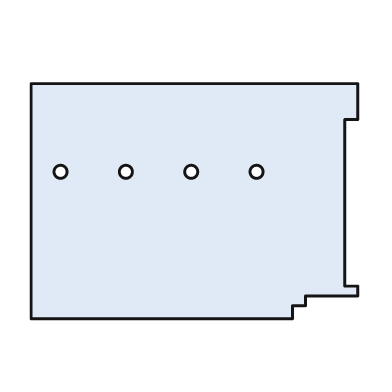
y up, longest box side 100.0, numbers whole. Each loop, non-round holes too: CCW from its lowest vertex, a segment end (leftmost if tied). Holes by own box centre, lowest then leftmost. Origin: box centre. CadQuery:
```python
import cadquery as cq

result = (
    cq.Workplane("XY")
    .moveTo(-50.0, -36.0)
    .lineTo(30.0, -36.0)
    .lineTo(30.0, -32.0)
    .lineTo(34.0, -32.0)
    .lineTo(34.0, -29.0)
    .lineTo(50.0, -29.0)
    .lineTo(50.0, -26.0)
    .lineTo(46.0, -26.0)
    .lineTo(46.0, 25.0)
    .lineTo(50.0, 25.0)
    .lineTo(50.0, 36.0)
    .lineTo(-50.0, 36.0)
    .close()
    .moveTo(-41.0, 9.0)
    .circle(2.0)
    .moveTo(-21.0, 9.0)
    .circle(2.0)
    .moveTo(-1.0, 9.0)
    .circle(2.0)
    .moveTo(19.0, 9.0)
    .circle(2.0)
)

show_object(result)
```